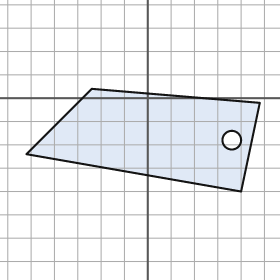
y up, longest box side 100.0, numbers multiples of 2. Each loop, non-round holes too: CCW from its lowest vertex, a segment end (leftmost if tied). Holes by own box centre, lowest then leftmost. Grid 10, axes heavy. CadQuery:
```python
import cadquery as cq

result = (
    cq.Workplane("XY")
    .moveTo(40.0, -40.0)
    .lineTo(48.0, -2.0)
    .lineTo(-24.0, 4.0)
    .lineTo(-52.0, -24.0)
    .close()
    .moveTo(36.0, -18.0)
    .circle(4.0)
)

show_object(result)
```